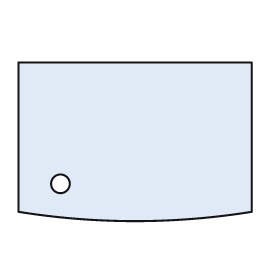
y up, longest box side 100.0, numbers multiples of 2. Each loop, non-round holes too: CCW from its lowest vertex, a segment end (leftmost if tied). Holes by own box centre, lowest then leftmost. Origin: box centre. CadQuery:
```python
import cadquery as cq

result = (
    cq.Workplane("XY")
    .moveTo(-50.0, -30.0)
    .threePointArc((0.0, -34.0), (50.0, -30.0))
    .lineTo(50.0, 34.0)
    .lineTo(-50.0, 34.0)
    .close()
    .moveTo(-32.0, -18.0)
    .circle(4.0)
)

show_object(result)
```